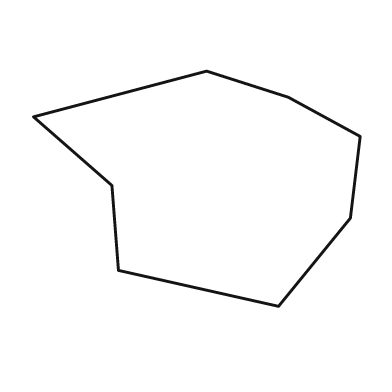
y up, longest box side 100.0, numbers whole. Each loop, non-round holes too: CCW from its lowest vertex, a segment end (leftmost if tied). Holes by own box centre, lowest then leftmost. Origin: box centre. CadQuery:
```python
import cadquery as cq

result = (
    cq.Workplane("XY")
    .moveTo(25.0, -36.0)
    .lineTo(47.0, -9.0)
    .lineTo(50.0, 16.0)
    .lineTo(28.0, 28.0)
    .lineTo(3.0, 36.0)
    .lineTo(-50.0, 22.0)
    .lineTo(-26.0, 1.0)
    .lineTo(-24.0, -25.0)
    .close()
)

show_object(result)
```